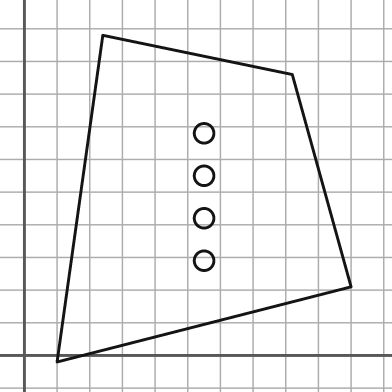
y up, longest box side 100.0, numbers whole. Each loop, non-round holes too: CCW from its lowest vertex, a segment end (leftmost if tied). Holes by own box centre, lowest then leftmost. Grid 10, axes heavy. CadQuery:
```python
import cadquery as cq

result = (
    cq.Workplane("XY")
    .moveTo(10.0, -2.0)
    .lineTo(100.0, 21.0)
    .lineTo(82.0, 86.0)
    .lineTo(24.0, 98.0)
    .close()
    .moveTo(55.0, 29.0)
    .circle(3.0)
    .moveTo(55.0, 42.0)
    .circle(3.0)
    .moveTo(55.0, 55.0)
    .circle(3.0)
    .moveTo(55.0, 68.0)
    .circle(3.0)
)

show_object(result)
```